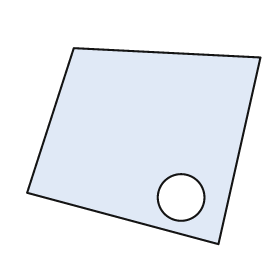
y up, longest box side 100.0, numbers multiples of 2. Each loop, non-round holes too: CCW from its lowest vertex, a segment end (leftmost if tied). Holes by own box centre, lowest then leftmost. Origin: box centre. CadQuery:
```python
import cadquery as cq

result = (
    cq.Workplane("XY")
    .moveTo(32.0, -42.0)
    .lineTo(50.0, 38.0)
    .lineTo(-30.0, 42.0)
    .lineTo(-50.0, -20.0)
    .close()
    .moveTo(16.0, -22.0)
    .circle(10.0)
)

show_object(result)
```